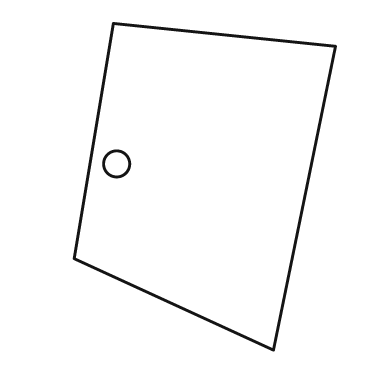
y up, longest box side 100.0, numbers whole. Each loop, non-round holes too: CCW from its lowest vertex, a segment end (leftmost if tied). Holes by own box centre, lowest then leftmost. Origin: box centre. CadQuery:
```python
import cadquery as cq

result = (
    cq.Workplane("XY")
    .moveTo(21.0, -50.0)
    .lineTo(40.0, 43.0)
    .lineTo(-28.0, 50.0)
    .lineTo(-40.0, -22.0)
    .close()
    .moveTo(-27.0, 7.0)
    .circle(4.0)
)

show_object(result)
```